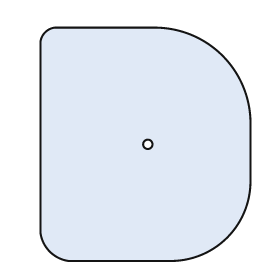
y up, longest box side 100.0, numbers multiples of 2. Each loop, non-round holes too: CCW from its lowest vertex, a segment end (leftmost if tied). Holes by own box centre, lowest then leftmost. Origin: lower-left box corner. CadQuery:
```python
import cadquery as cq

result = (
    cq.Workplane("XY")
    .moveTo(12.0, 0.0)
    .lineTo(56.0, 0.0)
    .threePointArc((80.0, 10.0), (90.0, 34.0))
    .lineTo(90.0, 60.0)
    .threePointArc((78.0, 88.0), (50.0, 100.0))
    .lineTo(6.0, 100.0)
    .threePointArc((2.0, 98.0), (0.0, 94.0))
    .lineTo(0.0, 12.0)
    .threePointArc((4.0, 4.0), (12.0, 0.0))
    .close()
    .moveTo(46.0, 50.0)
    .circle(2.0)
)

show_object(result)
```